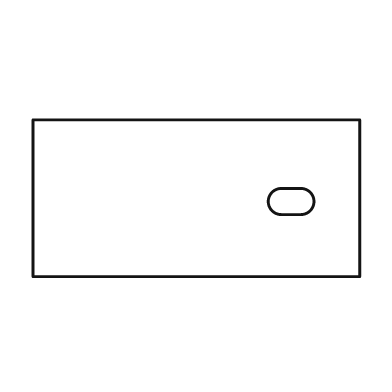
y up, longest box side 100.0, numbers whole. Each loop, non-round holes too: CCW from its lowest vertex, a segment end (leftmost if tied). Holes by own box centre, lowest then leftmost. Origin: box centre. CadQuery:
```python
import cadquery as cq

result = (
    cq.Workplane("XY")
    .moveTo(-50.0, -24.0)
    .lineTo(50.0, -24.0)
    .lineTo(50.0, 24.0)
    .lineTo(-50.0, 24.0)
    .close()
    .moveTo(26.0, -5.0)
    .lineTo(32.0, -5.0)
    .threePointArc((36.0, -1.0), (32.0, 3.0))
    .lineTo(26.0, 3.0)
    .threePointArc((22.0, -1.0), (26.0, -5.0))
    .close()
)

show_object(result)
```